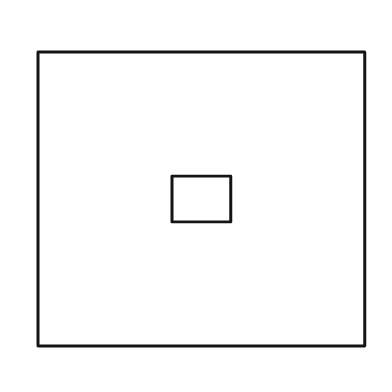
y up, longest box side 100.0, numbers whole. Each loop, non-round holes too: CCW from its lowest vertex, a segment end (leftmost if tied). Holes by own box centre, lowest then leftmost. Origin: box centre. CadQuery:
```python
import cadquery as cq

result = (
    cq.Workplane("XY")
    .moveTo(-50.0, -45.0)
    .lineTo(50.0, -45.0)
    .lineTo(50.0, 45.0)
    .lineTo(-50.0, 45.0)
    .close()
    .moveTo(-9.0, -7.0)
    .lineTo(9.0, -7.0)
    .lineTo(9.0, 7.0)
    .lineTo(-9.0, 7.0)
    .close()
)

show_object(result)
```